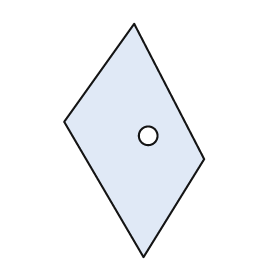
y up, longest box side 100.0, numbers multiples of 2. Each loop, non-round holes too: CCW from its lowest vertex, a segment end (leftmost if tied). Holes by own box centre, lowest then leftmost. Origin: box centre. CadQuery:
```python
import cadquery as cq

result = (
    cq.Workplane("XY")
    .moveTo(4.0, -50.0)
    .lineTo(30.0, -8.0)
    .lineTo(0.0, 50.0)
    .lineTo(-30.0, 8.0)
    .close()
    .moveTo(6.0, 2.0)
    .circle(4.0)
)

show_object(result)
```